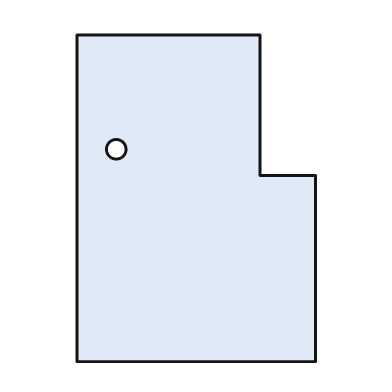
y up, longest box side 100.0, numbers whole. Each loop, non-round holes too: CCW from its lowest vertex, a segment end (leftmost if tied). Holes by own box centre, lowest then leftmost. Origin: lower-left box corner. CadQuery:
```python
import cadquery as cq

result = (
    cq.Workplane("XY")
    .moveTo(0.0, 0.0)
    .lineTo(73.0, 0.0)
    .lineTo(73.0, 57.0)
    .lineTo(56.0, 57.0)
    .lineTo(56.0, 100.0)
    .lineTo(0.0, 100.0)
    .close()
    .moveTo(12.0, 65.0)
    .circle(3.0)
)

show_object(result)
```